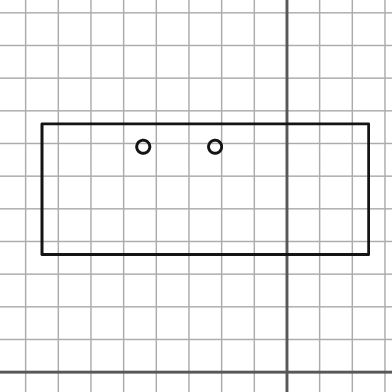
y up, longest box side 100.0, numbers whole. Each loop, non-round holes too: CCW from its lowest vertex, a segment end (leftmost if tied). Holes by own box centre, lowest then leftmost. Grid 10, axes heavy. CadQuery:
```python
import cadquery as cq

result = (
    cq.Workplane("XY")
    .moveTo(-75.0, 36.0)
    .lineTo(25.0, 36.0)
    .lineTo(25.0, 76.0)
    .lineTo(-75.0, 76.0)
    .close()
    .moveTo(-44.0, 69.0)
    .circle(2.0)
    .moveTo(-22.0, 69.0)
    .circle(2.0)
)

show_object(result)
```